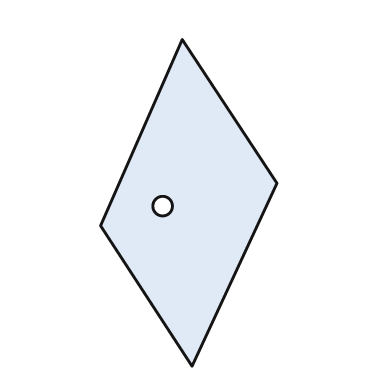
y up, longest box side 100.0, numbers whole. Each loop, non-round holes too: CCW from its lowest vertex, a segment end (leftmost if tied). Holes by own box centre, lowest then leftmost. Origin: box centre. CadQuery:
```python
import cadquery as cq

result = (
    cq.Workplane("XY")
    .moveTo(1.0, -50.0)
    .lineTo(27.0, 6.0)
    .lineTo(-2.0, 50.0)
    .lineTo(-27.0, -7.0)
    .close()
    .moveTo(-8.0, -1.0)
    .circle(3.0)
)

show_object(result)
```